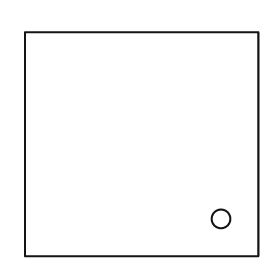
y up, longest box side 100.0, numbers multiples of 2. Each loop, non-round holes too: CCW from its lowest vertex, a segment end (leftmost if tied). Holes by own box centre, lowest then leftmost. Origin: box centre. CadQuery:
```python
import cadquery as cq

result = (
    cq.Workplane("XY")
    .moveTo(-50.0, -48.0)
    .lineTo(50.0, -48.0)
    .lineTo(50.0, 48.0)
    .lineTo(-50.0, 48.0)
    .close()
    .moveTo(34.0, -32.0)
    .circle(4.0)
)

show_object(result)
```